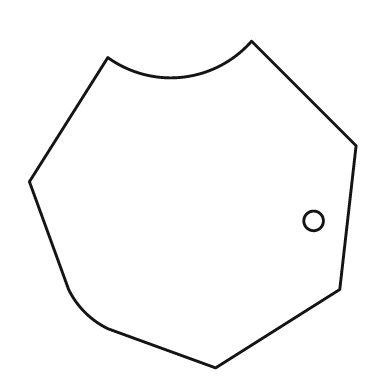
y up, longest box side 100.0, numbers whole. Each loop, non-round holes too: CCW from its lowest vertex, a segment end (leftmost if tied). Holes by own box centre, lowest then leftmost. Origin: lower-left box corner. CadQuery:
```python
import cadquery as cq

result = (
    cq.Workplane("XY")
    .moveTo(57.0, 0.0)
    .lineTo(95.0, 24.0)
    .lineTo(100.0, 68.0)
    .lineTo(68.0, 100.0)
    .threePointArc((47.0, 89.0), (24.0, 95.0))
    .lineTo(0.0, 57.0)
    .lineTo(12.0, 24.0)
    .threePointArc((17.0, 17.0), (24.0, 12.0))
    .close()
    .moveTo(87.0, 45.0)
    .circle(3.0)
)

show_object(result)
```